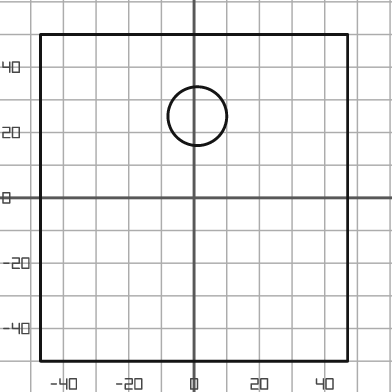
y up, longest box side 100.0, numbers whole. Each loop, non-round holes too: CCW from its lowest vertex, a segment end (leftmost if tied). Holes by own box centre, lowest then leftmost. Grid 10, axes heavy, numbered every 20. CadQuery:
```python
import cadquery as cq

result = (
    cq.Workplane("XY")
    .moveTo(-47.0, -50.0)
    .lineTo(47.0, -50.0)
    .lineTo(47.0, 50.0)
    .lineTo(-47.0, 50.0)
    .close()
    .moveTo(1.0, 25.0)
    .circle(9.0)
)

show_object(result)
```